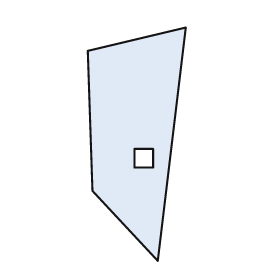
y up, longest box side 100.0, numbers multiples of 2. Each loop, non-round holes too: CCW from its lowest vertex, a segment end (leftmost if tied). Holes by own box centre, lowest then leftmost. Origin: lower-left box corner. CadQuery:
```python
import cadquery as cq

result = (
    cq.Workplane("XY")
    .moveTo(30.0, 0.0)
    .lineTo(42.0, 100.0)
    .lineTo(0.0, 90.0)
    .lineTo(2.0, 30.0)
    .close()
    .moveTo(20.0, 40.0)
    .lineTo(28.0, 40.0)
    .lineTo(28.0, 48.0)
    .lineTo(20.0, 48.0)
    .close()
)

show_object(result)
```